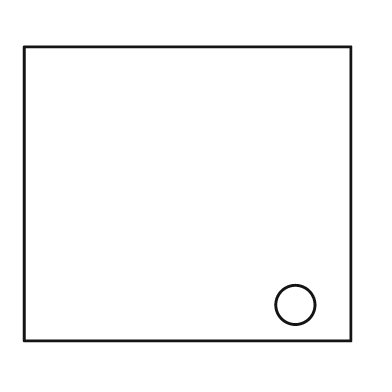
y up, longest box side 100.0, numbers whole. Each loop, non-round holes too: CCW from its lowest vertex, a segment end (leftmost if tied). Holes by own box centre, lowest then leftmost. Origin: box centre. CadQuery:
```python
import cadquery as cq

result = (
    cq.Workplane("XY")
    .moveTo(-50.0, -45.0)
    .lineTo(50.0, -45.0)
    .lineTo(50.0, 45.0)
    .lineTo(-50.0, 45.0)
    .close()
    .moveTo(33.0, -34.0)
    .circle(6.0)
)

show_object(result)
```